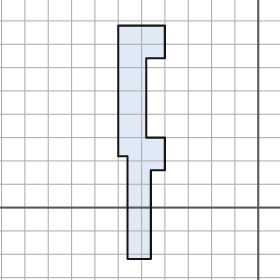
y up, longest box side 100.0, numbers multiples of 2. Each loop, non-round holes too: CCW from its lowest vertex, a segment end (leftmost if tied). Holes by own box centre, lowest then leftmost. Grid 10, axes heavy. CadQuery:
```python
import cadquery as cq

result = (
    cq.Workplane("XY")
    .moveTo(-56.0, -22.0)
    .lineTo(-46.0, -22.0)
    .lineTo(-46.0, 16.0)
    .lineTo(-40.0, 16.0)
    .lineTo(-40.0, 30.0)
    .lineTo(-48.0, 30.0)
    .lineTo(-48.0, 64.0)
    .lineTo(-40.0, 64.0)
    .lineTo(-40.0, 78.0)
    .lineTo(-60.0, 78.0)
    .lineTo(-60.0, 22.0)
    .lineTo(-56.0, 22.0)
    .close()
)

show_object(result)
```